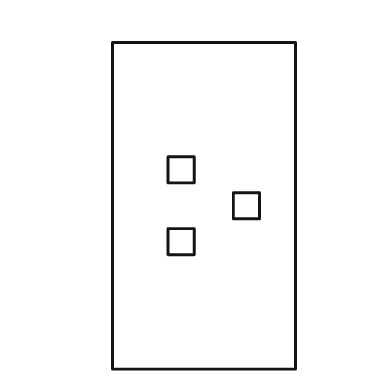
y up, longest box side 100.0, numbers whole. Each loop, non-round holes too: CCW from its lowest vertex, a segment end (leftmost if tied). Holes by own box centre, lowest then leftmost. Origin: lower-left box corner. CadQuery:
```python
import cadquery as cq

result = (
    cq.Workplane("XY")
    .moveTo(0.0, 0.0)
    .lineTo(56.0, 0.0)
    .lineTo(56.0, 100.0)
    .lineTo(0.0, 100.0)
    .close()
    .moveTo(17.0, 35.0)
    .lineTo(25.0, 35.0)
    .lineTo(25.0, 43.0)
    .lineTo(17.0, 43.0)
    .close()
    .moveTo(37.0, 46.0)
    .lineTo(45.0, 46.0)
    .lineTo(45.0, 54.0)
    .lineTo(37.0, 54.0)
    .close()
    .moveTo(17.0, 57.0)
    .lineTo(25.0, 57.0)
    .lineTo(25.0, 65.0)
    .lineTo(17.0, 65.0)
    .close()
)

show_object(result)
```